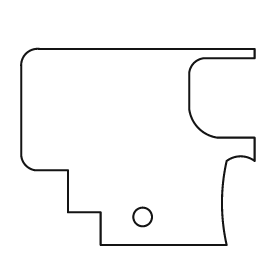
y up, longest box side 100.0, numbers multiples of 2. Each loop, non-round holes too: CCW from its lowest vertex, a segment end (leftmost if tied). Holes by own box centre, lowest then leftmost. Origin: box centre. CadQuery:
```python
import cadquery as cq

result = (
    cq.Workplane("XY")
    .moveTo(-16.0, -42.0)
    .lineTo(38.0, -42.0)
    .threePointArc((36.0, -24.0), (38.0, -6.0))
    .threePointArc((44.0, -4.0), (50.0, -6.0))
    .lineTo(50.0, 4.0)
    .lineTo(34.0, 4.0)
    .threePointArc((26.0, 8.0), (22.0, 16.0))
    .lineTo(22.0, 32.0)
    .threePointArc((24.0, 36.0), (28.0, 38.0))
    .lineTo(50.0, 38.0)
    .lineTo(50.0, 42.0)
    .lineTo(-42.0, 42.0)
    .threePointArc((-48.0, 40.0), (-50.0, 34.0))
    .lineTo(-50.0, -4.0)
    .threePointArc((-48.0, -8.0), (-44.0, -10.0))
    .lineTo(-30.0, -10.0)
    .lineTo(-30.0, -28.0)
    .lineTo(-16.0, -28.0)
    .close()
    .moveTo(2.0, -30.0)
    .circle(4.0)
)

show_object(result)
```